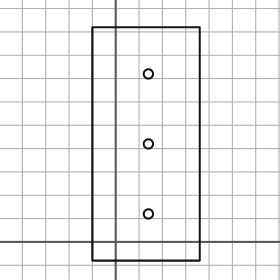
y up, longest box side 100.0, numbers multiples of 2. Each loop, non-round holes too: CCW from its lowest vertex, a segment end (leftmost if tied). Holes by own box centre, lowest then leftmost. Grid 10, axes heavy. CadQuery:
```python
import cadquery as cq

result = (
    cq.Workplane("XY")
    .moveTo(-10.0, -8.0)
    .lineTo(36.0, -8.0)
    .lineTo(36.0, 92.0)
    .lineTo(-10.0, 92.0)
    .close()
    .moveTo(14.0, 12.0)
    .circle(2.0)
    .moveTo(14.0, 42.0)
    .circle(2.0)
    .moveTo(14.0, 72.0)
    .circle(2.0)
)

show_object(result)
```